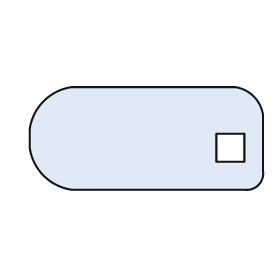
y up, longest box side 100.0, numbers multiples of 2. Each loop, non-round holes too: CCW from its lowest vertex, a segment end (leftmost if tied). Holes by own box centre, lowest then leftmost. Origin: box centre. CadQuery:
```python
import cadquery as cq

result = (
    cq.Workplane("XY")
    .moveTo(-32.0, -22.0)
    .lineTo(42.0, -22.0)
    .threePointArc((48.0, -20.0), (50.0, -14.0))
    .lineTo(50.0, 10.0)
    .threePointArc((46.0, 18.0), (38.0, 22.0))
    .lineTo(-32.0, 22.0)
    .threePointArc((-44.0, 16.0), (-50.0, 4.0))
    .lineTo(-50.0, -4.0)
    .threePointArc((-44.0, -16.0), (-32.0, -22.0))
    .close()
    .moveTo(30.0, -10.0)
    .lineTo(42.0, -10.0)
    .lineTo(42.0, 2.0)
    .lineTo(30.0, 2.0)
    .close()
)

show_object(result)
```